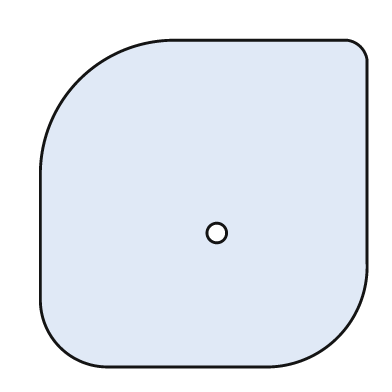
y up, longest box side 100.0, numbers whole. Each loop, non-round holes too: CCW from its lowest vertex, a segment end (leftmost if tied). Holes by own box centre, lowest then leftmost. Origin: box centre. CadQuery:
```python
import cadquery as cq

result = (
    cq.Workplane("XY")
    .moveTo(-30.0, -50.0)
    .lineTo(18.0, -50.0)
    .threePointArc((41.0, -41.0), (50.0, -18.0))
    .lineTo(50.0, 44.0)
    .threePointArc((48.0, 48.0), (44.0, 50.0))
    .lineTo(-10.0, 50.0)
    .threePointArc((-38.0, 38.0), (-50.0, 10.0))
    .lineTo(-50.0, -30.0)
    .threePointArc((-44.0, -44.0), (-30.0, -50.0))
    .close()
    .moveTo(4.0, -9.0)
    .circle(3.0)
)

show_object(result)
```